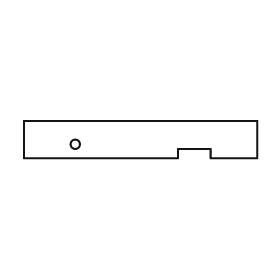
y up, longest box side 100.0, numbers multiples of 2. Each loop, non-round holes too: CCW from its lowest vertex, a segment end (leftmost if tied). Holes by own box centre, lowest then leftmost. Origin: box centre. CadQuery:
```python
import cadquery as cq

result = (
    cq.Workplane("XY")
    .moveTo(-50.0, -8.0)
    .lineTo(16.0, -8.0)
    .lineTo(16.0, -4.0)
    .lineTo(30.0, -4.0)
    .lineTo(30.0, -8.0)
    .lineTo(50.0, -8.0)
    .lineTo(50.0, 8.0)
    .lineTo(-50.0, 8.0)
    .close()
    .moveTo(-28.0, -2.0)
    .circle(2.0)
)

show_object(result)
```